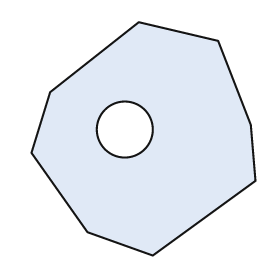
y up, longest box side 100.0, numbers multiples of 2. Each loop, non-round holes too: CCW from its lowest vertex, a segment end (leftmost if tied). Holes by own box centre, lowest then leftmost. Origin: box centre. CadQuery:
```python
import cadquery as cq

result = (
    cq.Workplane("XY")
    .moveTo(4.0, -50.0)
    .lineTo(48.0, -18.0)
    .lineTo(46.0, 6.0)
    .lineTo(32.0, 42.0)
    .lineTo(-2.0, 50.0)
    .lineTo(-40.0, 20.0)
    .lineTo(-48.0, -6.0)
    .lineTo(-24.0, -40.0)
    .close()
    .moveTo(-8.0, 4.0)
    .circle(12.0)
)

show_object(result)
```